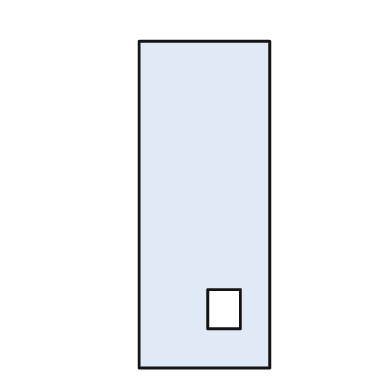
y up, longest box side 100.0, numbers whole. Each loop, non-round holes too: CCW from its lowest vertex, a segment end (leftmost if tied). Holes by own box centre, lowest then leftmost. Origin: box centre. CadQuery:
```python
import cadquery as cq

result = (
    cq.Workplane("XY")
    .moveTo(-20.0, -50.0)
    .lineTo(20.0, -50.0)
    .lineTo(20.0, 50.0)
    .lineTo(-20.0, 50.0)
    .close()
    .moveTo(1.0, -38.0)
    .lineTo(11.0, -38.0)
    .lineTo(11.0, -26.0)
    .lineTo(1.0, -26.0)
    .close()
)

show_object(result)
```